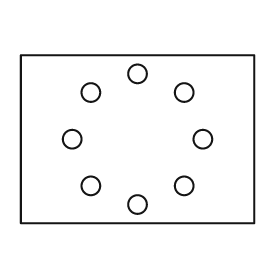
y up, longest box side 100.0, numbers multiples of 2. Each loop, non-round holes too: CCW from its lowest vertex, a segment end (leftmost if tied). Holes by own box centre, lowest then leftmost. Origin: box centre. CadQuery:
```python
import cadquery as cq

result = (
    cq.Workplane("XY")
    .moveTo(-50.0, -36.0)
    .lineTo(50.0, -36.0)
    .lineTo(50.0, 36.0)
    .lineTo(-50.0, 36.0)
    .close()
    .moveTo(0.0, -28.0)
    .circle(4.0)
    .moveTo(-20.0, -20.0)
    .circle(4.0)
    .moveTo(20.0, -20.0)
    .circle(4.0)
    .moveTo(-28.0, 0.0)
    .circle(4.0)
    .moveTo(28.0, 0.0)
    .circle(4.0)
    .moveTo(-20.0, 20.0)
    .circle(4.0)
    .moveTo(20.0, 20.0)
    .circle(4.0)
    .moveTo(0.0, 28.0)
    .circle(4.0)
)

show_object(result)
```